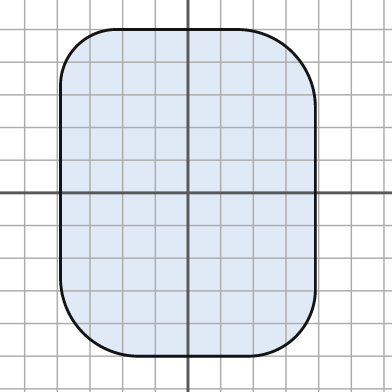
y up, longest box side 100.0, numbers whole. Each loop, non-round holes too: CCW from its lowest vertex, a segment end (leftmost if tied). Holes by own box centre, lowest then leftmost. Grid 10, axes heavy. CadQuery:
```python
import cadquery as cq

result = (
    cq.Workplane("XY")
    .moveTo(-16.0, -50.0)
    .lineTo(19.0, -50.0)
    .threePointArc((33.0, -44.0), (39.0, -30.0))
    .lineTo(39.0, 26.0)
    .threePointArc((32.0, 43.0), (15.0, 50.0))
    .lineTo(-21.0, 50.0)
    .threePointArc((-34.0, 45.0), (-39.0, 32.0))
    .lineTo(-39.0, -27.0)
    .threePointArc((-32.0, -43.0), (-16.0, -50.0))
    .close()
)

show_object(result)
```